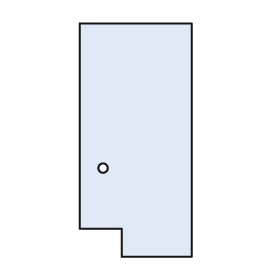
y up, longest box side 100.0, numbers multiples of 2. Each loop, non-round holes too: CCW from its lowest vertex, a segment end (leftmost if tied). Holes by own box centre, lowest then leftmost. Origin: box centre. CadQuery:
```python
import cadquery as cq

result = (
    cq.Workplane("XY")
    .moveTo(-6.0, -50.0)
    .lineTo(24.0, -50.0)
    .lineTo(24.0, 50.0)
    .lineTo(-24.0, 50.0)
    .lineTo(-24.0, -38.0)
    .lineTo(-6.0, -38.0)
    .close()
    .moveTo(-14.0, -12.0)
    .circle(2.0)
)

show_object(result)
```